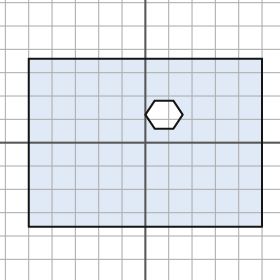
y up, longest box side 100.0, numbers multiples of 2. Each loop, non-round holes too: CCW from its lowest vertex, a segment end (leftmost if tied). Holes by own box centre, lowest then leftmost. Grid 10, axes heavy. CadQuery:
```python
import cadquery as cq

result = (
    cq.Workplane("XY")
    .moveTo(-50.0, -36.0)
    .lineTo(50.0, -36.0)
    .lineTo(50.0, 36.0)
    .lineTo(-50.0, 36.0)
    .close()
    .moveTo(4.0, 6.0)
    .lineTo(12.0, 6.0)
    .lineTo(16.0, 12.0)
    .lineTo(12.0, 18.0)
    .lineTo(4.0, 18.0)
    .lineTo(0.0, 12.0)
    .close()
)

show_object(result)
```